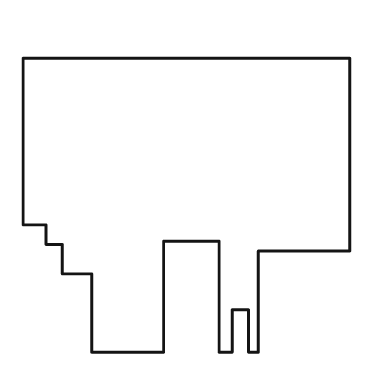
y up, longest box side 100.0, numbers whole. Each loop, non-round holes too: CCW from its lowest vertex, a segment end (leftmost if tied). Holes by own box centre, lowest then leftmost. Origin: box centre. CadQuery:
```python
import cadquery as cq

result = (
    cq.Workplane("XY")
    .moveTo(-29.0, -45.0)
    .lineTo(-7.0, -45.0)
    .lineTo(-7.0, -11.0)
    .lineTo(10.0, -11.0)
    .lineTo(10.0, -45.0)
    .lineTo(14.0, -45.0)
    .lineTo(14.0, -32.0)
    .lineTo(19.0, -32.0)
    .lineTo(19.0, -45.0)
    .lineTo(22.0, -45.0)
    .lineTo(22.0, -14.0)
    .lineTo(50.0, -14.0)
    .lineTo(50.0, 45.0)
    .lineTo(-50.0, 45.0)
    .lineTo(-50.0, -6.0)
    .lineTo(-43.0, -6.0)
    .lineTo(-43.0, -12.0)
    .lineTo(-38.0, -12.0)
    .lineTo(-38.0, -21.0)
    .lineTo(-29.0, -21.0)
    .close()
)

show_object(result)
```